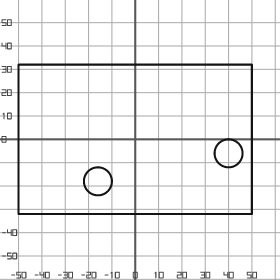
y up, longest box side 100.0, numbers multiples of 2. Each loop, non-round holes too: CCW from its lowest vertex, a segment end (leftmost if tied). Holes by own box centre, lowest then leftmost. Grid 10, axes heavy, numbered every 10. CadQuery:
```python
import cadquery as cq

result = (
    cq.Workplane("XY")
    .moveTo(-50.0, -32.0)
    .lineTo(50.0, -32.0)
    .lineTo(50.0, 32.0)
    .lineTo(-50.0, 32.0)
    .close()
    .moveTo(-16.0, -18.0)
    .circle(6.0)
    .moveTo(40.0, -6.0)
    .circle(6.0)
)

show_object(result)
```